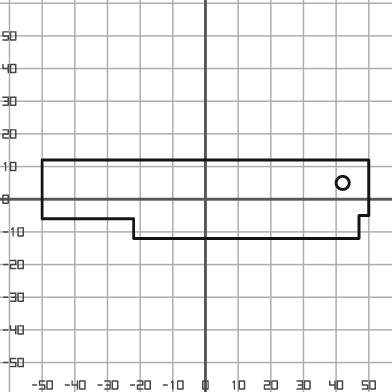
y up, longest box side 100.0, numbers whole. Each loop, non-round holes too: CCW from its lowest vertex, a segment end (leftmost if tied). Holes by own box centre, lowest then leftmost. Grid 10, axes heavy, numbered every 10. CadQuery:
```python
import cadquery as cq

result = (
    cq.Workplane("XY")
    .moveTo(-22.0, -12.0)
    .lineTo(47.0, -12.0)
    .lineTo(47.0, -5.0)
    .lineTo(50.0, -5.0)
    .lineTo(50.0, 12.0)
    .lineTo(-50.0, 12.0)
    .lineTo(-50.0, -6.0)
    .lineTo(-22.0, -6.0)
    .close()
    .moveTo(42.0, 5.0)
    .circle(2.0)
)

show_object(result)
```